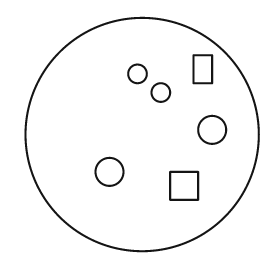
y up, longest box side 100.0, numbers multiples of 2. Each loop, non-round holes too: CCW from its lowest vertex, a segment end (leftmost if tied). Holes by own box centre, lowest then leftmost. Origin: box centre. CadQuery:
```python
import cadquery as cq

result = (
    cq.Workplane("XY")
    .moveTo(0.0, 0.0)
    .circle(50.0)
    .moveTo(12.0, -28.0)
    .lineTo(24.0, -28.0)
    .lineTo(24.0, -16.0)
    .lineTo(12.0, -16.0)
    .close()
    .moveTo(-14.0, -16.0)
    .circle(6.0)
    .moveTo(30.0, 2.0)
    .circle(6.0)
    .moveTo(8.0, 18.0)
    .circle(4.0)
    .moveTo(-2.0, 26.0)
    .circle(4.0)
    .moveTo(22.0, 22.0)
    .lineTo(30.0, 22.0)
    .lineTo(30.0, 34.0)
    .lineTo(22.0, 34.0)
    .close()
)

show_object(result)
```